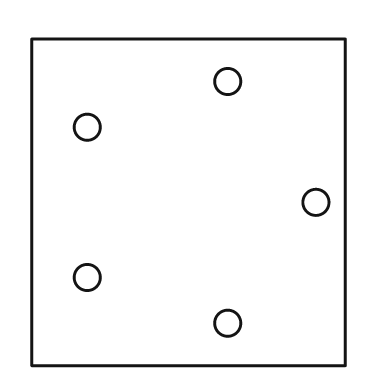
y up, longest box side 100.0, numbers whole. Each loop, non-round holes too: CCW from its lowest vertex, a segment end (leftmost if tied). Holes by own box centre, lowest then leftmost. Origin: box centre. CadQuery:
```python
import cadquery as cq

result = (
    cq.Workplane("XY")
    .moveTo(-48.0, -50.0)
    .lineTo(48.0, -50.0)
    .lineTo(48.0, 50.0)
    .lineTo(-48.0, 50.0)
    .close()
    .moveTo(12.0, -37.0)
    .circle(4.0)
    .moveTo(-31.0, -23.0)
    .circle(4.0)
    .moveTo(39.0, 0.0)
    .circle(4.0)
    .moveTo(-31.0, 23.0)
    .circle(4.0)
    .moveTo(12.0, 37.0)
    .circle(4.0)
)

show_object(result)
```